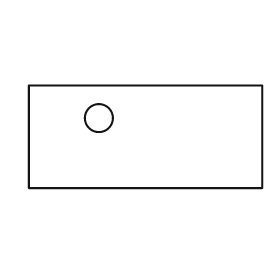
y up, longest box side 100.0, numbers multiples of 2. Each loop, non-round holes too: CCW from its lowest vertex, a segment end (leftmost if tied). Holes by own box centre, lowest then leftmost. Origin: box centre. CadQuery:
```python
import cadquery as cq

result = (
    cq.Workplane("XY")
    .moveTo(-50.0, -22.0)
    .lineTo(50.0, -22.0)
    .lineTo(50.0, 22.0)
    .lineTo(-50.0, 22.0)
    .close()
    .moveTo(-20.0, 8.0)
    .circle(6.0)
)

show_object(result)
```